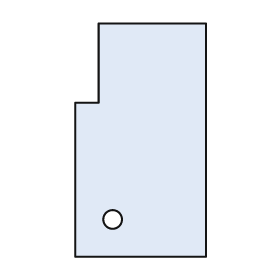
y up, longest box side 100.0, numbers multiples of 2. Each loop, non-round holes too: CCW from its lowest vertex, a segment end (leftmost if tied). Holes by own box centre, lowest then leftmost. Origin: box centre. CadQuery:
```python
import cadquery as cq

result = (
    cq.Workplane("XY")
    .moveTo(-28.0, -50.0)
    .lineTo(28.0, -50.0)
    .lineTo(28.0, 50.0)
    .lineTo(-18.0, 50.0)
    .lineTo(-18.0, 16.0)
    .lineTo(-28.0, 16.0)
    .close()
    .moveTo(-12.0, -34.0)
    .circle(4.0)
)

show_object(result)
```